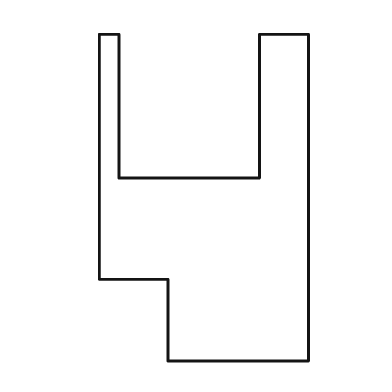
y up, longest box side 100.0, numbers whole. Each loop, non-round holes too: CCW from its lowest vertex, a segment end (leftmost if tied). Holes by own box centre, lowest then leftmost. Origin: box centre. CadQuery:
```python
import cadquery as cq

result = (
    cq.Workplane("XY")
    .moveTo(-11.0, -50.0)
    .lineTo(32.0, -50.0)
    .lineTo(32.0, 50.0)
    .lineTo(17.0, 50.0)
    .lineTo(17.0, 6.0)
    .lineTo(-26.0, 6.0)
    .lineTo(-26.0, 50.0)
    .lineTo(-32.0, 50.0)
    .lineTo(-32.0, -25.0)
    .lineTo(-11.0, -25.0)
    .close()
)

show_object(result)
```